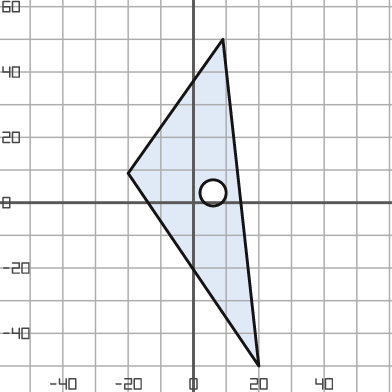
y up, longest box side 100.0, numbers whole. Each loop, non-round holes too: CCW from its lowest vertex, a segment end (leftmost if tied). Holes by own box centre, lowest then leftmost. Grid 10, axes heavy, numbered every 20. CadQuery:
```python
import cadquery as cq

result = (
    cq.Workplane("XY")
    .moveTo(20.0, -50.0)
    .lineTo(9.0, 50.0)
    .lineTo(-20.0, 9.0)
    .close()
    .moveTo(6.0, 3.0)
    .circle(4.0)
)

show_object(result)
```